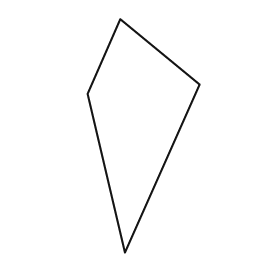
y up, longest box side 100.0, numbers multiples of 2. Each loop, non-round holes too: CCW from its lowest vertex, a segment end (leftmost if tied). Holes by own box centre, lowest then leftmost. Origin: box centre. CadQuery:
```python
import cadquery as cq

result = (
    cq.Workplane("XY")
    .moveTo(-8.0, -50.0)
    .lineTo(24.0, 22.0)
    .lineTo(-10.0, 50.0)
    .lineTo(-24.0, 18.0)
    .close()
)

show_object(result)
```